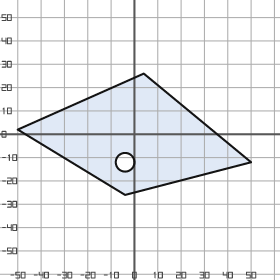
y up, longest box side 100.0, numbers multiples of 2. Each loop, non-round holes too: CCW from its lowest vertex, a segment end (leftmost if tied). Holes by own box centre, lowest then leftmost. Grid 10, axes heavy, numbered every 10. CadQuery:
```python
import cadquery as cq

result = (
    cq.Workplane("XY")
    .moveTo(-4.0, -26.0)
    .lineTo(50.0, -12.0)
    .lineTo(4.0, 26.0)
    .lineTo(-50.0, 2.0)
    .close()
    .moveTo(-4.0, -12.0)
    .circle(4.0)
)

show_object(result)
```